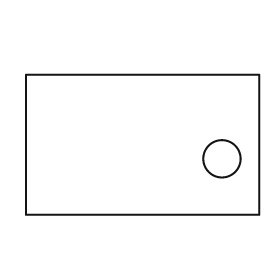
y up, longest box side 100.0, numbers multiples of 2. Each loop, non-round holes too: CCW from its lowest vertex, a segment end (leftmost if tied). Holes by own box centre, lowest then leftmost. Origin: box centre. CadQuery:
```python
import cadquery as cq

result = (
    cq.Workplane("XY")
    .moveTo(-50.0, -30.0)
    .lineTo(50.0, -30.0)
    .lineTo(50.0, 30.0)
    .lineTo(-50.0, 30.0)
    .close()
    .moveTo(34.0, -6.0)
    .circle(8.0)
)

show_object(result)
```